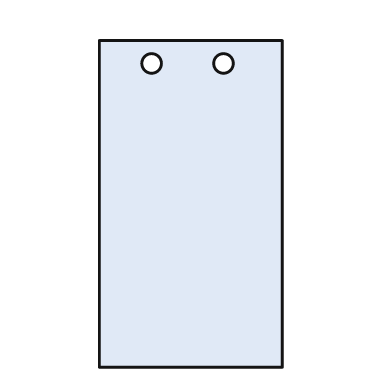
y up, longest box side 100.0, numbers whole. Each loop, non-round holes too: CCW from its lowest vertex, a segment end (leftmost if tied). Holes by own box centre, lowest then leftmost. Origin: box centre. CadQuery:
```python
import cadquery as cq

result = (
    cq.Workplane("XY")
    .moveTo(-28.0, -50.0)
    .lineTo(28.0, -50.0)
    .lineTo(28.0, 50.0)
    .lineTo(-28.0, 50.0)
    .close()
    .moveTo(-12.0, 43.0)
    .circle(3.0)
    .moveTo(10.0, 43.0)
    .circle(3.0)
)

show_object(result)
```